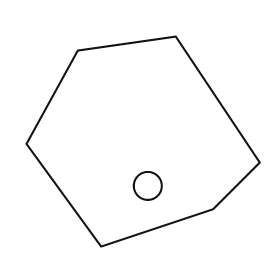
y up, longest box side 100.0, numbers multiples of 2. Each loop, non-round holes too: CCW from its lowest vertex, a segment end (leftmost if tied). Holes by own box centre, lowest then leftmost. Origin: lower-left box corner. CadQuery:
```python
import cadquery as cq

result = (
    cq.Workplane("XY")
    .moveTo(32.0, 0.0)
    .lineTo(80.0, 16.0)
    .lineTo(100.0, 36.0)
    .lineTo(64.0, 90.0)
    .lineTo(22.0, 84.0)
    .lineTo(0.0, 44.0)
    .close()
    .moveTo(52.0, 26.0)
    .circle(6.0)
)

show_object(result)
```